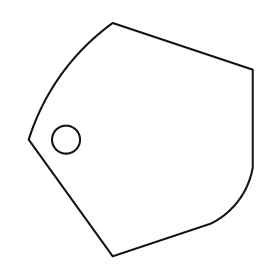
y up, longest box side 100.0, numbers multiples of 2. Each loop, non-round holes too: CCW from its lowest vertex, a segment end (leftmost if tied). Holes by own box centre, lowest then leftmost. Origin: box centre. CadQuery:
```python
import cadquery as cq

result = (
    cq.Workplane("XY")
    .moveTo(-12.0, -50.0)
    .lineTo(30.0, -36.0)
    .threePointArc((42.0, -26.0), (48.0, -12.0))
    .lineTo(48.0, 30.0)
    .lineTo(-12.0, 50.0)
    .threePointArc((-34.0, 28.0), (-48.0, 0.0))
    .close()
    .moveTo(-32.0, 0.0)
    .circle(6.0)
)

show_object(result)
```